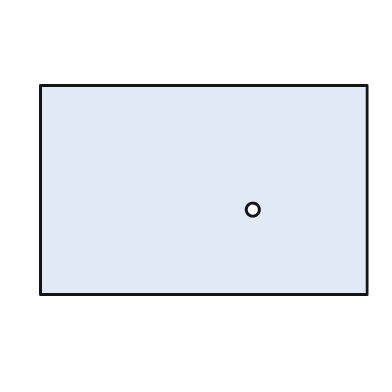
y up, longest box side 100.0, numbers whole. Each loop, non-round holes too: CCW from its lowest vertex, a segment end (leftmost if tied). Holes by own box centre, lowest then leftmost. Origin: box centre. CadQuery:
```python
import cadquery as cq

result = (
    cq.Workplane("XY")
    .moveTo(-50.0, -32.0)
    .lineTo(50.0, -32.0)
    .lineTo(50.0, 32.0)
    .lineTo(-50.0, 32.0)
    .close()
    .moveTo(15.0, -6.0)
    .circle(2.0)
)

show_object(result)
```